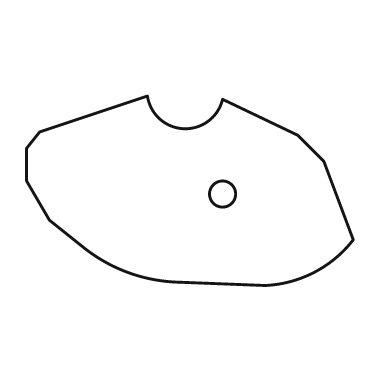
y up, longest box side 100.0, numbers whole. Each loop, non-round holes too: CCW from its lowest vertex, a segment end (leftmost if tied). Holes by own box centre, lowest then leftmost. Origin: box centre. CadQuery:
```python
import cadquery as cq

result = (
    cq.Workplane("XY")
    .moveTo(23.0, -29.0)
    .threePointArc((38.0, -25.0), (50.0, -15.0))
    .lineTo(41.0, 9.0)
    .lineTo(33.0, 17.0)
    .lineTo(10.0, 28.0)
    .threePointArc((-2.0, 19.0), (-13.0, 29.0))
    .lineTo(-46.0, 18.0)
    .lineTo(-50.0, 13.0)
    .lineTo(-50.0, 3.0)
    .lineTo(-43.0, -9.0)
    .lineTo(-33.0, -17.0)
    .threePointArc((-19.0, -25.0), (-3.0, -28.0))
    .close()
    .moveTo(10.0, -1.0)
    .circle(4.0)
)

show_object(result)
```